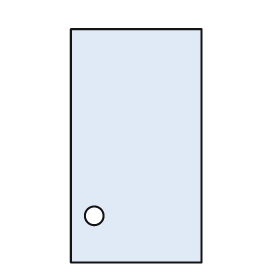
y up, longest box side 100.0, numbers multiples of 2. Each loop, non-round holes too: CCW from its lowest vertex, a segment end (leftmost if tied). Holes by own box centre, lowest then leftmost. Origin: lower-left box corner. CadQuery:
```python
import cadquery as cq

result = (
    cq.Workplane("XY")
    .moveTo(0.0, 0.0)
    .lineTo(56.0, 0.0)
    .lineTo(56.0, 100.0)
    .lineTo(0.0, 100.0)
    .close()
    .moveTo(10.0, 20.0)
    .circle(4.0)
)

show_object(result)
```